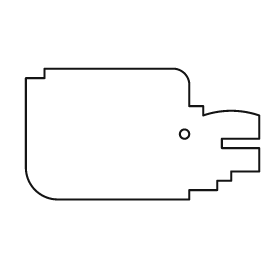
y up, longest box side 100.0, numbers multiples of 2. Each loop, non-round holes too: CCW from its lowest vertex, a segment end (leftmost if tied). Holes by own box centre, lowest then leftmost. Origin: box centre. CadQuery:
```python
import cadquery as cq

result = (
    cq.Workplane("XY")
    .moveTo(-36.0, -28.0)
    .lineTo(20.0, -28.0)
    .lineTo(20.0, -24.0)
    .lineTo(32.0, -24.0)
    .lineTo(32.0, -20.0)
    .lineTo(38.0, -20.0)
    .lineTo(38.0, -16.0)
    .lineTo(50.0, -16.0)
    .lineTo(50.0, -6.0)
    .lineTo(34.0, -6.0)
    .lineTo(34.0, -2.0)
    .lineTo(50.0, -2.0)
    .lineTo(50.0, 8.0)
    .threePointArc((38.0, 10.0), (26.0, 8.0))
    .lineTo(26.0, 12.0)
    .lineTo(20.0, 12.0)
    .lineTo(20.0, 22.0)
    .threePointArc((18.0, 26.0), (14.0, 28.0))
    .lineTo(-42.0, 28.0)
    .lineTo(-42.0, 24.0)
    .lineTo(-50.0, 24.0)
    .lineTo(-50.0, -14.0)
    .threePointArc((-46.0, -24.0), (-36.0, -28.0))
    .close()
    .moveTo(18.0, 0.0)
    .circle(2.0)
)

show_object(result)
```